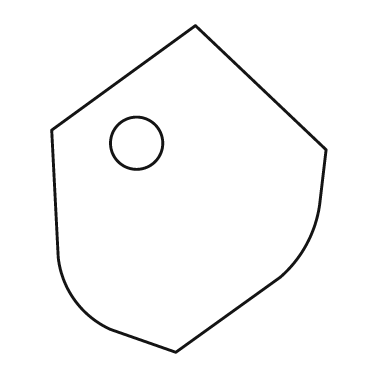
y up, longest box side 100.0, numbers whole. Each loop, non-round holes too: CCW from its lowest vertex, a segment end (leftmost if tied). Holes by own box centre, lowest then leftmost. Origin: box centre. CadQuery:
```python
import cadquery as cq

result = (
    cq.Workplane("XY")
    .moveTo(-4.0, -50.0)
    .lineTo(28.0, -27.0)
    .threePointArc((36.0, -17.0), (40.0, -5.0))
    .lineTo(42.0, 12.0)
    .lineTo(2.0, 50.0)
    .lineTo(-42.0, 18.0)
    .lineTo(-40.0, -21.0)
    .threePointArc((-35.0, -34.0), (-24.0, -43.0))
    .close()
    .moveTo(-16.0, 14.0)
    .circle(8.0)
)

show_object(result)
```